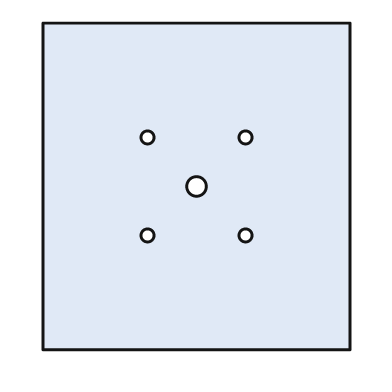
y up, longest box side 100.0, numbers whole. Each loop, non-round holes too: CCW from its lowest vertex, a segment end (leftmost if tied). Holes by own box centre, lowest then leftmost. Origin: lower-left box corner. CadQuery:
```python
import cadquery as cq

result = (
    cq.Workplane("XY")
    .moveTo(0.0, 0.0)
    .lineTo(94.0, 0.0)
    .lineTo(94.0, 100.0)
    .lineTo(0.0, 100.0)
    .close()
    .moveTo(32.0, 35.0)
    .circle(2.0)
    .moveTo(62.0, 35.0)
    .circle(2.0)
    .moveTo(47.0, 50.0)
    .circle(3.0)
    .moveTo(32.0, 65.0)
    .circle(2.0)
    .moveTo(62.0, 65.0)
    .circle(2.0)
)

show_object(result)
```